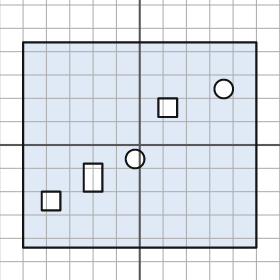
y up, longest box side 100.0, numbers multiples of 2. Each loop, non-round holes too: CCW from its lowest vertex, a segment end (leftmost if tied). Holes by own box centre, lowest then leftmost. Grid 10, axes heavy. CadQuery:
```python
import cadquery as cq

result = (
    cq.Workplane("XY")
    .moveTo(-50.0, -44.0)
    .lineTo(50.0, -44.0)
    .lineTo(50.0, 44.0)
    .lineTo(-50.0, 44.0)
    .close()
    .moveTo(-42.0, -28.0)
    .lineTo(-34.0, -28.0)
    .lineTo(-34.0, -20.0)
    .lineTo(-42.0, -20.0)
    .close()
    .moveTo(-24.0, -20.0)
    .lineTo(-16.0, -20.0)
    .lineTo(-16.0, -8.0)
    .lineTo(-24.0, -8.0)
    .close()
    .moveTo(-2.0, -6.0)
    .circle(4.0)
    .moveTo(8.0, 12.0)
    .lineTo(16.0, 12.0)
    .lineTo(16.0, 20.0)
    .lineTo(8.0, 20.0)
    .close()
    .moveTo(36.0, 24.0)
    .circle(4.0)
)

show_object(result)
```